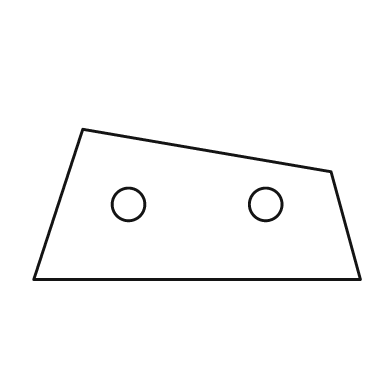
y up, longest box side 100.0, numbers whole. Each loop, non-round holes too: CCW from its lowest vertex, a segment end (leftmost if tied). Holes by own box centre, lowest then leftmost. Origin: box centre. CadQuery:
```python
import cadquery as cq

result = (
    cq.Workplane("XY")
    .moveTo(-50.0, -23.0)
    .lineTo(50.0, -23.0)
    .lineTo(41.0, 10.0)
    .lineTo(-35.0, 23.0)
    .close()
    .moveTo(-21.0, 0.0)
    .circle(5.0)
    .moveTo(21.0, 0.0)
    .circle(5.0)
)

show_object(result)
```